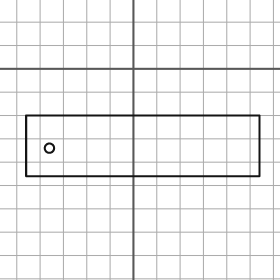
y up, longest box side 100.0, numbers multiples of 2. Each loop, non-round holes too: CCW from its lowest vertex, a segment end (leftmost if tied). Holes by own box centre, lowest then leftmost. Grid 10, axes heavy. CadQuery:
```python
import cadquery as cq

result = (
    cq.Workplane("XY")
    .moveTo(-46.0, -46.0)
    .lineTo(54.0, -46.0)
    .lineTo(54.0, -20.0)
    .lineTo(-46.0, -20.0)
    .close()
    .moveTo(-36.0, -34.0)
    .circle(2.0)
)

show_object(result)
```